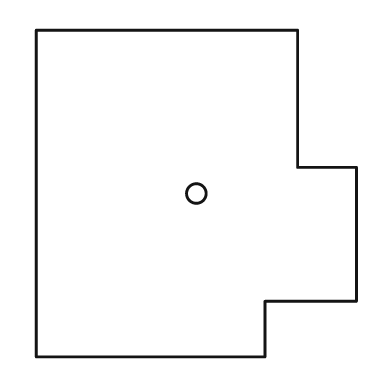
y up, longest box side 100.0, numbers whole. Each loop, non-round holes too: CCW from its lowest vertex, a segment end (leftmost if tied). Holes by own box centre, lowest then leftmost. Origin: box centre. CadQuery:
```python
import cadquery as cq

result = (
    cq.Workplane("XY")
    .moveTo(-49.0, -50.0)
    .lineTo(21.0, -50.0)
    .lineTo(21.0, -33.0)
    .lineTo(49.0, -33.0)
    .lineTo(49.0, 8.0)
    .lineTo(31.0, 8.0)
    .lineTo(31.0, 50.0)
    .lineTo(-49.0, 50.0)
    .close()
    .moveTo(0.0, 0.0)
    .circle(3.0)
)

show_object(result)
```